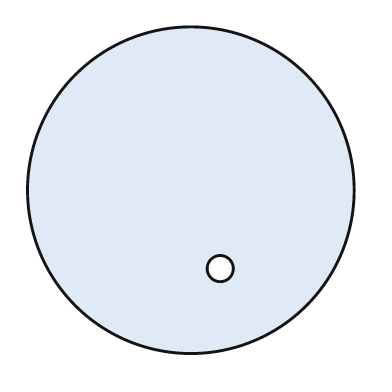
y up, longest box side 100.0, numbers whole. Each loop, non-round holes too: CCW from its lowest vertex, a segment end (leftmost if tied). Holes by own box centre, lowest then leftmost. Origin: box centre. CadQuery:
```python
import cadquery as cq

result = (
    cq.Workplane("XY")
    .moveTo(0.0, 0.0)
    .circle(50.0)
    .moveTo(9.0, -24.0)
    .circle(4.0)
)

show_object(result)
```